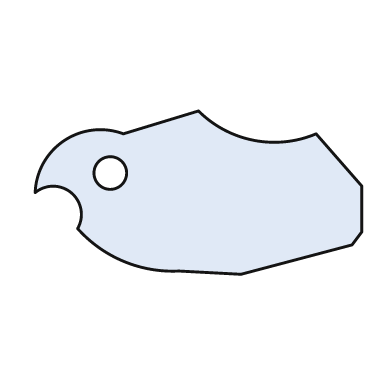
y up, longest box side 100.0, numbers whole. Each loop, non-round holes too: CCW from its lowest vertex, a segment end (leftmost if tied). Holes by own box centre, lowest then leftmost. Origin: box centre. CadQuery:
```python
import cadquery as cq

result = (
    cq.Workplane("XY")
    .moveTo(13.0, -25.0)
    .lineTo(47.0, -16.0)
    .lineTo(50.0, -12.0)
    .lineTo(50.0, 2.0)
    .lineTo(36.0, 18.0)
    .threePointArc((17.0, 16.0), (0.0, 25.0))
    .lineTo(-23.0, 18.0)
    .threePointArc((-41.0, 16.0), (-50.0, 0.0))
    .threePointArc((-39.0, 0.0), (-37.0, -11.0))
    .threePointArc((-23.0, -21.0), (-6.0, -24.0))
    .close()
    .moveTo(-27.0, 6.0)
    .circle(5.0)
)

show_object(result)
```